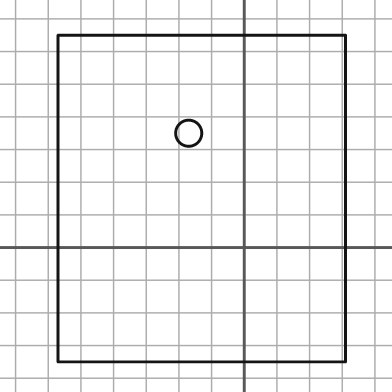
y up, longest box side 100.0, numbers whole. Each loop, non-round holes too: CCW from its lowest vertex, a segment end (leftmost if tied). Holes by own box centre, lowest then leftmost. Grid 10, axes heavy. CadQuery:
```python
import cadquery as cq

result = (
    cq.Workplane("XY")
    .moveTo(-57.0, -35.0)
    .lineTo(31.0, -35.0)
    .lineTo(31.0, 65.0)
    .lineTo(-57.0, 65.0)
    .close()
    .moveTo(-17.0, 35.0)
    .circle(4.0)
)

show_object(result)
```